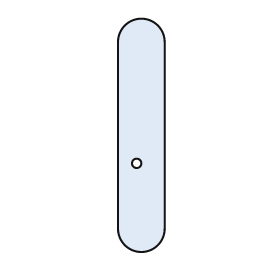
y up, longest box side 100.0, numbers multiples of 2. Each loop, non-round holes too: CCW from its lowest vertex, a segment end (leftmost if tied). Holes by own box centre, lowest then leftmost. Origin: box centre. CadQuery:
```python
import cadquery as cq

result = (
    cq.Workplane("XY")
    .moveTo(-10.0, -40.0)
    .threePointArc((0.0, -50.0), (10.0, -40.0))
    .lineTo(10.0, 40.0)
    .threePointArc((0.0, 50.0), (-10.0, 40.0))
    .close()
    .moveTo(-2.0, -12.0)
    .circle(2.0)
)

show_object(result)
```